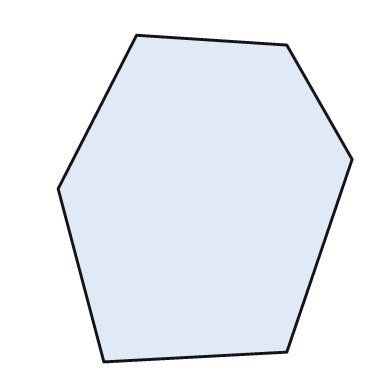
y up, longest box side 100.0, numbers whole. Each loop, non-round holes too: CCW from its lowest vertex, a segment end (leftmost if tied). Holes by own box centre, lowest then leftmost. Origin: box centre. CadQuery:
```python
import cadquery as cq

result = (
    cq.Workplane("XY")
    .moveTo(-31.0, -50.0)
    .lineTo(25.0, -47.0)
    .lineTo(45.0, 12.0)
    .lineTo(25.0, 47.0)
    .lineTo(-21.0, 50.0)
    .lineTo(-45.0, 3.0)
    .close()
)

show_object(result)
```